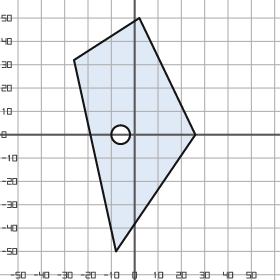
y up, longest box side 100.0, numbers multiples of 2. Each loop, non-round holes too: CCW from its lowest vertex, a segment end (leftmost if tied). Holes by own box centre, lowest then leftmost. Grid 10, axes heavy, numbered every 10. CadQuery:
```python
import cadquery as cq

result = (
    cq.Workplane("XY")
    .moveTo(-8.0, -50.0)
    .lineTo(26.0, 0.0)
    .lineTo(2.0, 50.0)
    .lineTo(-26.0, 32.0)
    .close()
    .moveTo(-6.0, 0.0)
    .circle(4.0)
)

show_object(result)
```